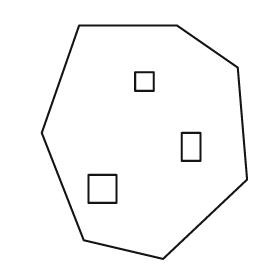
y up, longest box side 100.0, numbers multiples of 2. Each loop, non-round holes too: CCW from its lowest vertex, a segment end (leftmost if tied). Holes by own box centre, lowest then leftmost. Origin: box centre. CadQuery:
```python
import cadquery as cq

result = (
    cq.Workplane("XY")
    .moveTo(8.0, -50.0)
    .lineTo(44.0, -16.0)
    .lineTo(40.0, 32.0)
    .lineTo(14.0, 50.0)
    .lineTo(-28.0, 50.0)
    .lineTo(-44.0, 4.0)
    .lineTo(-26.0, -42.0)
    .close()
    .moveTo(-24.0, -26.0)
    .lineTo(-12.0, -26.0)
    .lineTo(-12.0, -14.0)
    .lineTo(-24.0, -14.0)
    .close()
    .moveTo(16.0, -8.0)
    .lineTo(24.0, -8.0)
    .lineTo(24.0, 4.0)
    .lineTo(16.0, 4.0)
    .close()
    .moveTo(-4.0, 22.0)
    .lineTo(4.0, 22.0)
    .lineTo(4.0, 30.0)
    .lineTo(-4.0, 30.0)
    .close()
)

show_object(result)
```